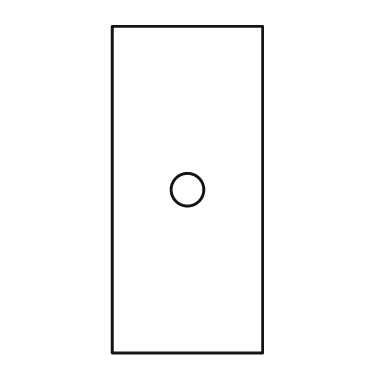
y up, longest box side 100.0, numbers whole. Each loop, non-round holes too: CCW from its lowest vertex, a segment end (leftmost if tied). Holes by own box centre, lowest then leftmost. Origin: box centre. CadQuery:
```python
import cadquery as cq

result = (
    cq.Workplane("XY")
    .moveTo(-23.0, -50.0)
    .lineTo(23.0, -50.0)
    .lineTo(23.0, 50.0)
    .lineTo(-23.0, 50.0)
    .close()
    .moveTo(0.0, 0.0)
    .circle(5.0)
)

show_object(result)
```